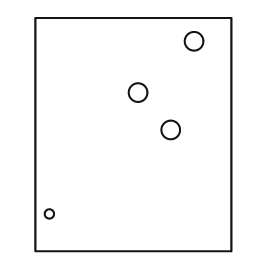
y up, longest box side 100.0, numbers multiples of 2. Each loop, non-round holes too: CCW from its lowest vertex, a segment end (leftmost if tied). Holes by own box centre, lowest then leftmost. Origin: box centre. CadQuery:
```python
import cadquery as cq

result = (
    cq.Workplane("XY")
    .moveTo(-42.0, -50.0)
    .lineTo(42.0, -50.0)
    .lineTo(42.0, 50.0)
    .lineTo(-42.0, 50.0)
    .close()
    .moveTo(-36.0, -34.0)
    .circle(2.0)
    .moveTo(16.0, 2.0)
    .circle(4.0)
    .moveTo(2.0, 18.0)
    .circle(4.0)
    .moveTo(26.0, 40.0)
    .circle(4.0)
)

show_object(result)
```